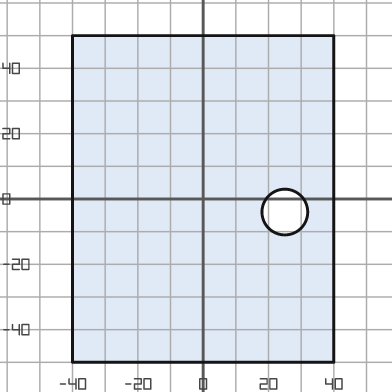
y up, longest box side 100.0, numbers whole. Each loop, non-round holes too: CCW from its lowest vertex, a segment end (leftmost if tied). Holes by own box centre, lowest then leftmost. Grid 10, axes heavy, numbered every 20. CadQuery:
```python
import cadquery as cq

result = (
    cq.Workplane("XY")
    .moveTo(-40.0, -50.0)
    .lineTo(40.0, -50.0)
    .lineTo(40.0, 50.0)
    .lineTo(-40.0, 50.0)
    .close()
    .moveTo(25.0, -4.0)
    .circle(7.0)
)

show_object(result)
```